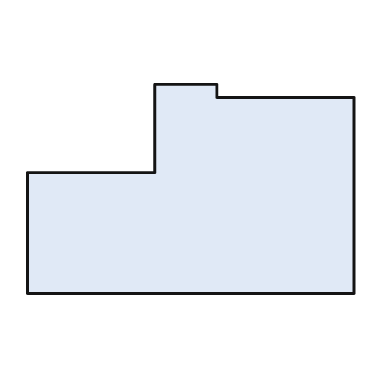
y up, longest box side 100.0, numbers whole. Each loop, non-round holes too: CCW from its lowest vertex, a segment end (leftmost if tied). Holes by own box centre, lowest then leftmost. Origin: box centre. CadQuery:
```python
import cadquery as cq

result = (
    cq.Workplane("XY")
    .moveTo(-50.0, -32.0)
    .lineTo(50.0, -32.0)
    .lineTo(50.0, 28.0)
    .lineTo(8.0, 28.0)
    .lineTo(8.0, 32.0)
    .lineTo(-11.0, 32.0)
    .lineTo(-11.0, 5.0)
    .lineTo(-50.0, 5.0)
    .close()
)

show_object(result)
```